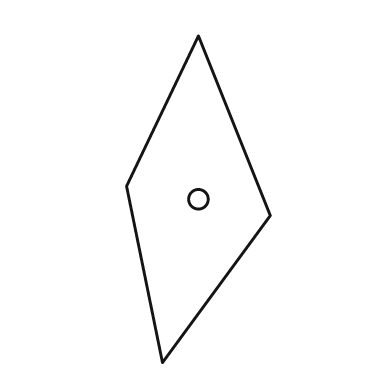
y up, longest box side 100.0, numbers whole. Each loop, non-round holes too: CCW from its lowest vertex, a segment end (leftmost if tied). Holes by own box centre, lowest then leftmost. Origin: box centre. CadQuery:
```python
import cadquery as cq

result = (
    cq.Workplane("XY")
    .moveTo(-11.0, -50.0)
    .lineTo(22.0, -5.0)
    .lineTo(0.0, 50.0)
    .lineTo(-22.0, 4.0)
    .close()
    .moveTo(0.0, 0.0)
    .circle(3.0)
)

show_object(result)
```